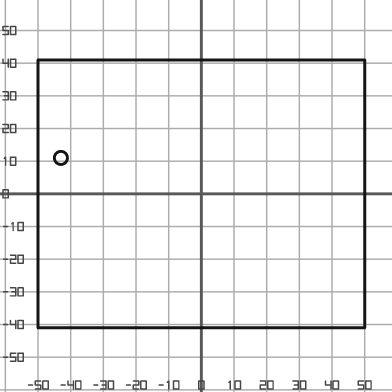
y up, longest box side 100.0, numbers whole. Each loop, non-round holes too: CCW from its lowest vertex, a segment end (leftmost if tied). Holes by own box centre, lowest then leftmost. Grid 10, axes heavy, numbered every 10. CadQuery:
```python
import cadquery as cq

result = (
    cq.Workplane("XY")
    .moveTo(-50.0, -41.0)
    .lineTo(50.0, -41.0)
    .lineTo(50.0, 41.0)
    .lineTo(-50.0, 41.0)
    .close()
    .moveTo(-43.0, 11.0)
    .circle(2.0)
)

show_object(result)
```